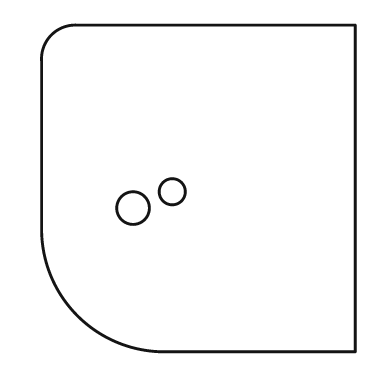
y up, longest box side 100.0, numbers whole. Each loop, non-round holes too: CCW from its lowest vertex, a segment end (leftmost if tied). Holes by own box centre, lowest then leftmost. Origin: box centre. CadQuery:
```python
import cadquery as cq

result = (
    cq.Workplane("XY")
    .moveTo(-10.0, -50.0)
    .lineTo(48.0, -50.0)
    .lineTo(48.0, 50.0)
    .lineTo(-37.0, 50.0)
    .threePointArc((-45.0, 47.0), (-48.0, 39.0))
    .lineTo(-48.0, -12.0)
    .threePointArc((-37.0, -39.0), (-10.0, -50.0))
    .close()
    .moveTo(-20.0, -6.0)
    .circle(5.0)
    .moveTo(-8.0, -1.0)
    .circle(4.0)
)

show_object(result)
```